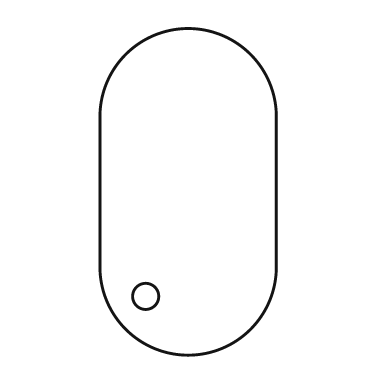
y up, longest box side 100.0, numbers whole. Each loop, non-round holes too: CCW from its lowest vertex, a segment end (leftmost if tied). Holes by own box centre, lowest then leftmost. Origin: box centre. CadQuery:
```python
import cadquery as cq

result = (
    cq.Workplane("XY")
    .moveTo(-27.0, -23.0)
    .threePointArc((0.0, -50.0), (27.0, -23.0))
    .lineTo(27.0, 23.0)
    .threePointArc((0.0, 50.0), (-27.0, 23.0))
    .close()
    .moveTo(-13.0, -32.0)
    .circle(4.0)
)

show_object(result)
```